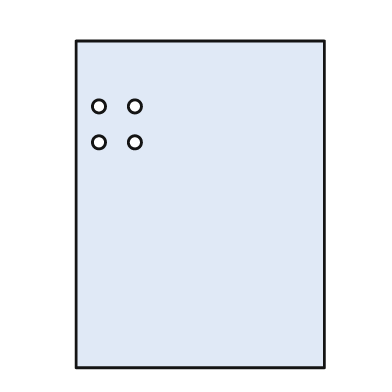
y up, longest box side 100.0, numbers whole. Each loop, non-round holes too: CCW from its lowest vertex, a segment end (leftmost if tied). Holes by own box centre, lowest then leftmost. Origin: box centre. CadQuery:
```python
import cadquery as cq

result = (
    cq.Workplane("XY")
    .moveTo(-38.0, -50.0)
    .lineTo(38.0, -50.0)
    .lineTo(38.0, 50.0)
    .lineTo(-38.0, 50.0)
    .close()
    .moveTo(-31.0, 19.0)
    .circle(2.0)
    .moveTo(-20.0, 19.0)
    .circle(2.0)
    .moveTo(-31.0, 30.0)
    .circle(2.0)
    .moveTo(-20.0, 30.0)
    .circle(2.0)
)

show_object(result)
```